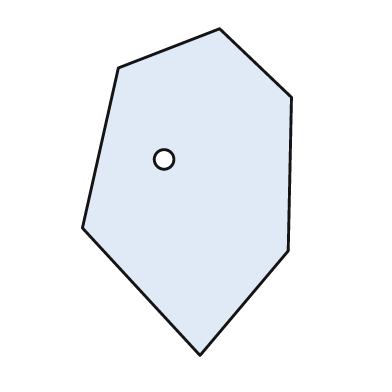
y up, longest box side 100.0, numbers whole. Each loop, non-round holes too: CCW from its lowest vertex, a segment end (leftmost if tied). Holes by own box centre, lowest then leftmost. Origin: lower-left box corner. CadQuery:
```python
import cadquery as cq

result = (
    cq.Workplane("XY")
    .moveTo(36.0, 0.0)
    .lineTo(63.0, 32.0)
    .lineTo(64.0, 79.0)
    .lineTo(42.0, 100.0)
    .lineTo(11.0, 88.0)
    .lineTo(0.0, 39.0)
    .close()
    .moveTo(25.0, 60.0)
    .circle(3.0)
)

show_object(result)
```